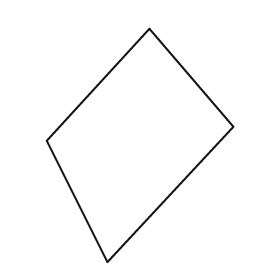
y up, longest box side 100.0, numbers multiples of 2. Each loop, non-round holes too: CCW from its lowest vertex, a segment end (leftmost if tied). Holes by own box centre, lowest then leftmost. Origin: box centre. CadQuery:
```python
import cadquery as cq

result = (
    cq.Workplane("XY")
    .moveTo(-14.0, -50.0)
    .lineTo(40.0, 8.0)
    .lineTo(4.0, 50.0)
    .lineTo(-40.0, 2.0)
    .close()
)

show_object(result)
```